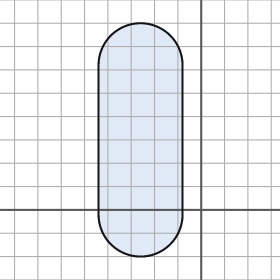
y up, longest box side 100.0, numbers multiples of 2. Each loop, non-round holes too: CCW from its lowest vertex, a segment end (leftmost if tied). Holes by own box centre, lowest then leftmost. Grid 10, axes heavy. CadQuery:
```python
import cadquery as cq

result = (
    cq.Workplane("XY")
    .moveTo(-44.0, -2.0)
    .threePointArc((-26.0, -20.0), (-8.0, -2.0))
    .lineTo(-8.0, 62.0)
    .threePointArc((-26.0, 80.0), (-44.0, 62.0))
    .close()
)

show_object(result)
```